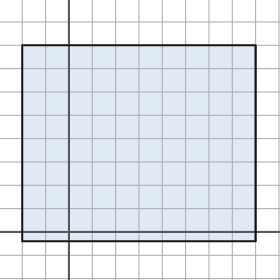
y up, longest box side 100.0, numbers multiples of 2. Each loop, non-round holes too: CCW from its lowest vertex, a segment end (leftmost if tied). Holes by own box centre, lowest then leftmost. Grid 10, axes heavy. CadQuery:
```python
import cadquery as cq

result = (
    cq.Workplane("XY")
    .moveTo(-20.0, -4.0)
    .lineTo(80.0, -4.0)
    .lineTo(80.0, 80.0)
    .lineTo(-20.0, 80.0)
    .close()
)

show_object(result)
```